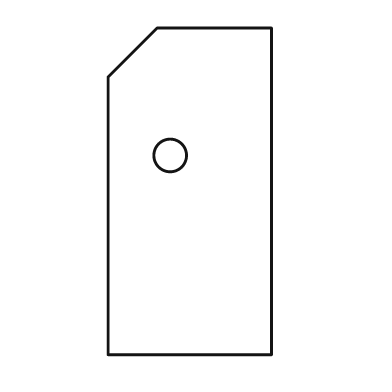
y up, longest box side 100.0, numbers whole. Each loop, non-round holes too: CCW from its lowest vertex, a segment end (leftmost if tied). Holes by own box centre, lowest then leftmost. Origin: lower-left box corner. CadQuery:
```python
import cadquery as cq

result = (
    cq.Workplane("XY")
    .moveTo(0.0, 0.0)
    .lineTo(50.0, 0.0)
    .lineTo(50.0, 100.0)
    .lineTo(15.0, 100.0)
    .lineTo(0.0, 85.0)
    .close()
    .moveTo(19.0, 61.0)
    .circle(5.0)
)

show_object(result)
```